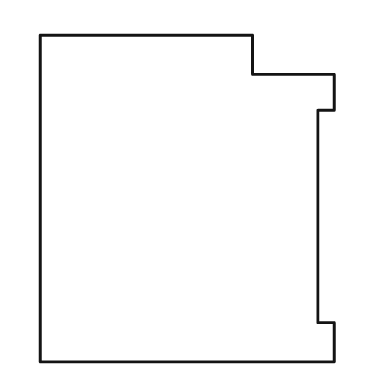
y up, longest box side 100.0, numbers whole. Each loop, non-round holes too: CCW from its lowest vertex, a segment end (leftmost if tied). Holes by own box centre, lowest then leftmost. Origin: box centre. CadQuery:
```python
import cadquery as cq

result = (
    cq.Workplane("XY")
    .moveTo(-45.0, -50.0)
    .lineTo(45.0, -50.0)
    .lineTo(45.0, -38.0)
    .lineTo(40.0, -38.0)
    .lineTo(40.0, 27.0)
    .lineTo(45.0, 27.0)
    .lineTo(45.0, 38.0)
    .lineTo(20.0, 38.0)
    .lineTo(20.0, 50.0)
    .lineTo(-45.0, 50.0)
    .close()
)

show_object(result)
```